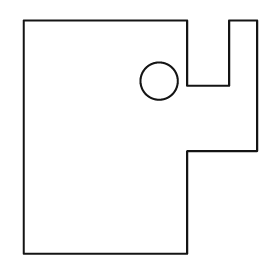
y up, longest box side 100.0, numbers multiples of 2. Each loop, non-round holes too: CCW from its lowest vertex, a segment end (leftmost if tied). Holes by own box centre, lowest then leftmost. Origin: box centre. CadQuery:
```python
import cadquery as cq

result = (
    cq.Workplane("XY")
    .moveTo(-50.0, -50.0)
    .lineTo(20.0, -50.0)
    .lineTo(20.0, -6.0)
    .lineTo(50.0, -6.0)
    .lineTo(50.0, 50.0)
    .lineTo(38.0, 50.0)
    .lineTo(38.0, 22.0)
    .lineTo(20.0, 22.0)
    .lineTo(20.0, 50.0)
    .lineTo(-50.0, 50.0)
    .close()
    .moveTo(8.0, 24.0)
    .circle(8.0)
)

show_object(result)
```